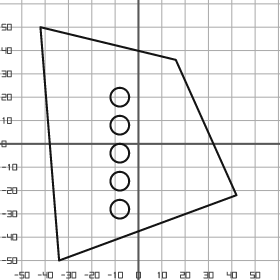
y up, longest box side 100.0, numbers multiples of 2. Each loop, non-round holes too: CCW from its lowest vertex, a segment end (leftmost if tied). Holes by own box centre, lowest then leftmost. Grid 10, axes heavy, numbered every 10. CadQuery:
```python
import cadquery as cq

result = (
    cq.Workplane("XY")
    .moveTo(-34.0, -50.0)
    .lineTo(42.0, -22.0)
    .lineTo(16.0, 36.0)
    .lineTo(-42.0, 50.0)
    .close()
    .moveTo(-8.0, -28.0)
    .circle(4.0)
    .moveTo(-8.0, -16.0)
    .circle(4.0)
    .moveTo(-8.0, -4.0)
    .circle(4.0)
    .moveTo(-8.0, 8.0)
    .circle(4.0)
    .moveTo(-8.0, 20.0)
    .circle(4.0)
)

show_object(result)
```